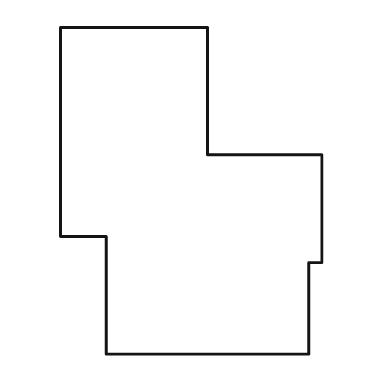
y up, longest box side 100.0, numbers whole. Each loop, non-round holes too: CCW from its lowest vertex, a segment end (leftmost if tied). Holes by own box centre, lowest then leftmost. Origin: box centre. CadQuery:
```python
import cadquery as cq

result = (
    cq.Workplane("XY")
    .moveTo(-26.0, -50.0)
    .lineTo(36.0, -50.0)
    .lineTo(36.0, -22.0)
    .lineTo(40.0, -22.0)
    .lineTo(40.0, 11.0)
    .lineTo(5.0, 11.0)
    .lineTo(5.0, 50.0)
    .lineTo(-40.0, 50.0)
    .lineTo(-40.0, -14.0)
    .lineTo(-26.0, -14.0)
    .close()
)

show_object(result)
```